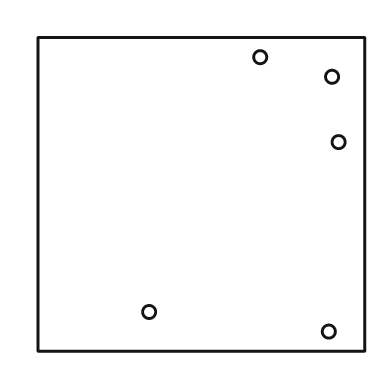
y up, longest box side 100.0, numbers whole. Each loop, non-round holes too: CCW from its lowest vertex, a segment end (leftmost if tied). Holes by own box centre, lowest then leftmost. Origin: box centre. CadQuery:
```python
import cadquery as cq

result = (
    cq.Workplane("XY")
    .moveTo(-50.0, -48.0)
    .lineTo(50.0, -48.0)
    .lineTo(50.0, 48.0)
    .lineTo(-50.0, 48.0)
    .close()
    .moveTo(39.0, -42.0)
    .circle(2.0)
    .moveTo(-16.0, -36.0)
    .circle(2.0)
    .moveTo(42.0, 16.0)
    .circle(2.0)
    .moveTo(40.0, 36.0)
    .circle(2.0)
    .moveTo(18.0, 42.0)
    .circle(2.0)
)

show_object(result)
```